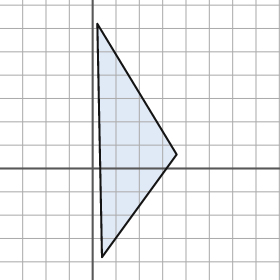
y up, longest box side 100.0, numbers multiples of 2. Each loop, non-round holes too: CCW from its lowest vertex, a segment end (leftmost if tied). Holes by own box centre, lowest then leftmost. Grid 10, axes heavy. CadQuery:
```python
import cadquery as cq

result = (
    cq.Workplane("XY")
    .moveTo(4.0, -38.0)
    .lineTo(36.0, 6.0)
    .lineTo(2.0, 62.0)
    .close()
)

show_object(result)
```